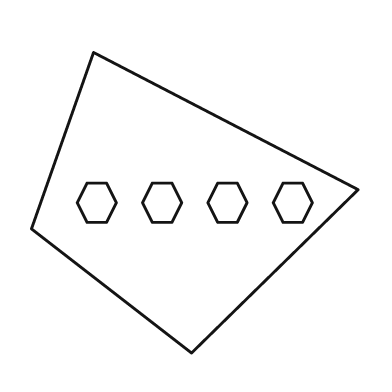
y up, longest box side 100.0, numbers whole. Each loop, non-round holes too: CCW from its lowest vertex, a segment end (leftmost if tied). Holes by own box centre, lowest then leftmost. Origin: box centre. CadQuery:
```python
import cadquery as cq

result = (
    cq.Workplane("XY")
    .moveTo(-1.0, -46.0)
    .lineTo(50.0, 4.0)
    .lineTo(-31.0, 46.0)
    .lineTo(-50.0, -8.0)
    .close()
    .moveTo(-33.0, -6.0)
    .lineTo(-27.0, -6.0)
    .lineTo(-24.0, 0.0)
    .lineTo(-27.0, 6.0)
    .lineTo(-33.0, 6.0)
    .lineTo(-36.0, 0.0)
    .close()
    .moveTo(-13.0, -6.0)
    .lineTo(-7.0, -6.0)
    .lineTo(-4.0, 0.0)
    .lineTo(-7.0, 6.0)
    .lineTo(-13.0, 6.0)
    .lineTo(-16.0, 0.0)
    .close()
    .moveTo(7.0, -6.0)
    .lineTo(13.0, -6.0)
    .lineTo(16.0, 0.0)
    .lineTo(13.0, 6.0)
    .lineTo(7.0, 6.0)
    .lineTo(4.0, 0.0)
    .close()
    .moveTo(27.0, -6.0)
    .lineTo(33.0, -6.0)
    .lineTo(36.0, 0.0)
    .lineTo(33.0, 6.0)
    .lineTo(27.0, 6.0)
    .lineTo(24.0, 0.0)
    .close()
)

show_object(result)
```